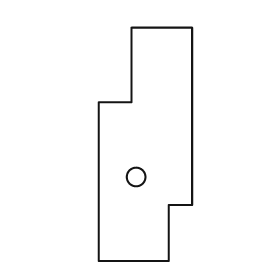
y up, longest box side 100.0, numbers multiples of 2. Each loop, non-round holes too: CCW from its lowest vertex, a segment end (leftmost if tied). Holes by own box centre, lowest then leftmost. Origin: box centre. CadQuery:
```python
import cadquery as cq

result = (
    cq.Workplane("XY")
    .moveTo(-20.0, -50.0)
    .lineTo(10.0, -50.0)
    .lineTo(10.0, -26.0)
    .lineTo(20.0, -26.0)
    .lineTo(20.0, 50.0)
    .lineTo(-6.0, 50.0)
    .lineTo(-6.0, 18.0)
    .lineTo(-20.0, 18.0)
    .close()
    .moveTo(-4.0, -14.0)
    .circle(4.0)
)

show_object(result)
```